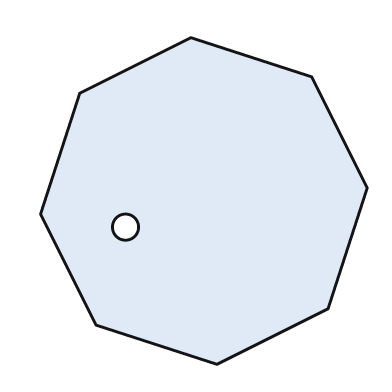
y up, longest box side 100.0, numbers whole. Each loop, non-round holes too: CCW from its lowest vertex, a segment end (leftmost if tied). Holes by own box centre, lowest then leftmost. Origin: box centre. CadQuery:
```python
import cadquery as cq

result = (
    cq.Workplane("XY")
    .moveTo(4.0, -50.0)
    .lineTo(38.0, -33.0)
    .lineTo(50.0, 4.0)
    .lineTo(33.0, 38.0)
    .lineTo(-4.0, 50.0)
    .lineTo(-38.0, 33.0)
    .lineTo(-50.0, -4.0)
    .lineTo(-33.0, -38.0)
    .close()
    .moveTo(-24.0, -8.0)
    .circle(4.0)
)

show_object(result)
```